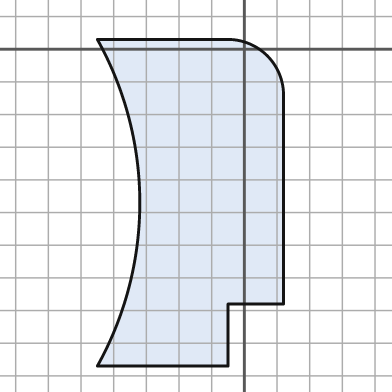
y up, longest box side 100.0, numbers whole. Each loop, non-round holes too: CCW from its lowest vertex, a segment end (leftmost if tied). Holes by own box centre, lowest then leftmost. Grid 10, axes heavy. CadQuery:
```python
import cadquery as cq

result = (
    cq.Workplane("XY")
    .moveTo(-45.0, -97.0)
    .lineTo(-5.0, -97.0)
    .lineTo(-5.0, -78.0)
    .lineTo(12.0, -78.0)
    .lineTo(12.0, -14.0)
    .threePointArc((7.0, -2.0), (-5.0, 3.0))
    .lineTo(-45.0, 3.0)
    .threePointArc((-32.0, -47.0), (-45.0, -97.0))
    .close()
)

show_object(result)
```